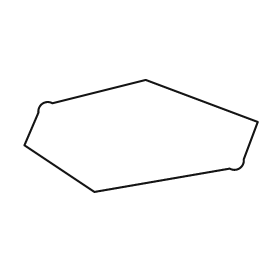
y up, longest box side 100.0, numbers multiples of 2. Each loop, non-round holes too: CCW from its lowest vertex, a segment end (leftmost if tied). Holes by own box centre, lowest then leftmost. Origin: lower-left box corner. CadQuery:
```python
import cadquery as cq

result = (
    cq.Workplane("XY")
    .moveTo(30.0, 0.0)
    .lineTo(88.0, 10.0)
    .threePointArc((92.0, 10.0), (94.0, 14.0))
    .lineTo(100.0, 30.0)
    .lineTo(52.0, 48.0)
    .lineTo(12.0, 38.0)
    .threePointArc((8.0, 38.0), (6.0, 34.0))
    .lineTo(0.0, 20.0)
    .close()
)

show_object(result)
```